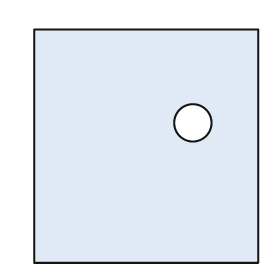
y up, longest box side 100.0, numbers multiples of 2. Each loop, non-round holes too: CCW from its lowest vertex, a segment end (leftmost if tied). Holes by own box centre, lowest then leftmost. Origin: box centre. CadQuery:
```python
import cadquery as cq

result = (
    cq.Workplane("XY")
    .moveTo(-48.0, -50.0)
    .lineTo(48.0, -50.0)
    .lineTo(48.0, 50.0)
    .lineTo(-48.0, 50.0)
    .close()
    .moveTo(20.0, 10.0)
    .circle(8.0)
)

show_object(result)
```